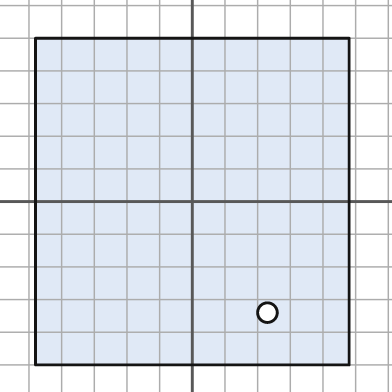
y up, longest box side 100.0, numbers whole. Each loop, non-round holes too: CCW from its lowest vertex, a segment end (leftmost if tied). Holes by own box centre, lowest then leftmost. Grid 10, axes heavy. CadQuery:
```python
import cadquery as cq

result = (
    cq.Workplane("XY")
    .moveTo(-48.0, -50.0)
    .lineTo(48.0, -50.0)
    .lineTo(48.0, 50.0)
    .lineTo(-48.0, 50.0)
    .close()
    .moveTo(23.0, -34.0)
    .circle(3.0)
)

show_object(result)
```